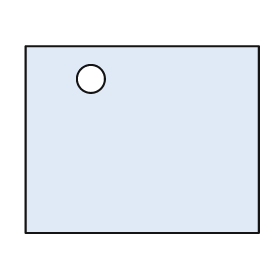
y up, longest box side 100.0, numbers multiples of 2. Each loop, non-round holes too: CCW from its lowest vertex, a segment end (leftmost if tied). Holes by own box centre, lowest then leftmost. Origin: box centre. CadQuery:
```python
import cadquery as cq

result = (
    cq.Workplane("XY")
    .moveTo(-50.0, -40.0)
    .lineTo(50.0, -40.0)
    .lineTo(50.0, 40.0)
    .lineTo(-50.0, 40.0)
    .close()
    .moveTo(-22.0, 26.0)
    .circle(6.0)
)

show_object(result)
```